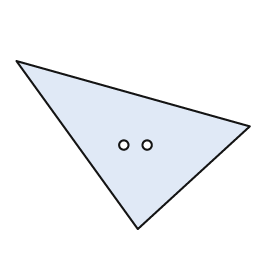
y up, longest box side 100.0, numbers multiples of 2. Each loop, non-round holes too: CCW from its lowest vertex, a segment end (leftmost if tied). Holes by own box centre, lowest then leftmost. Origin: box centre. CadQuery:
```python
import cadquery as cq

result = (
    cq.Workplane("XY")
    .moveTo(2.0, -36.0)
    .lineTo(50.0, 8.0)
    .lineTo(-50.0, 36.0)
    .close()
    .moveTo(-4.0, 0.0)
    .circle(2.0)
    .moveTo(6.0, 0.0)
    .circle(2.0)
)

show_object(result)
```